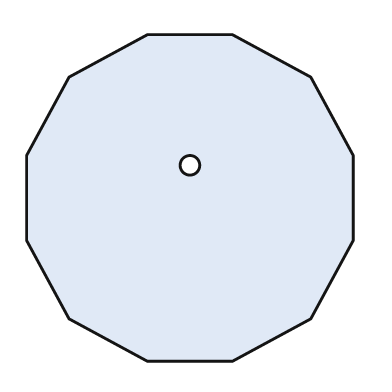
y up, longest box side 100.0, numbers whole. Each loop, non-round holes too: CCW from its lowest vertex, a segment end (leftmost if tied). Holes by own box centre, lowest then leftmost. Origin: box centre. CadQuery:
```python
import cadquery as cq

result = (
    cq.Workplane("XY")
    .moveTo(-13.0, -50.0)
    .lineTo(13.0, -50.0)
    .lineTo(37.0, -37.0)
    .lineTo(50.0, -13.0)
    .lineTo(50.0, 13.0)
    .lineTo(37.0, 37.0)
    .lineTo(13.0, 50.0)
    .lineTo(-13.0, 50.0)
    .lineTo(-37.0, 37.0)
    .lineTo(-50.0, 13.0)
    .lineTo(-50.0, -13.0)
    .lineTo(-37.0, -37.0)
    .close()
    .moveTo(0.0, 10.0)
    .circle(3.0)
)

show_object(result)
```